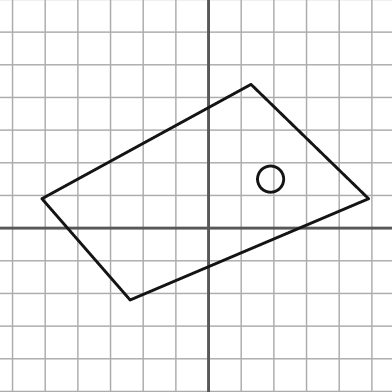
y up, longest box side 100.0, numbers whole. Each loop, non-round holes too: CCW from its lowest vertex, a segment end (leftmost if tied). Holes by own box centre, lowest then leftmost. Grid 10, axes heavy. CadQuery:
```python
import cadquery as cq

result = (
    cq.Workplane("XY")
    .moveTo(-24.0, -22.0)
    .lineTo(49.0, 9.0)
    .lineTo(13.0, 44.0)
    .lineTo(-51.0, 9.0)
    .close()
    .moveTo(19.0, 15.0)
    .circle(4.0)
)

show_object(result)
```